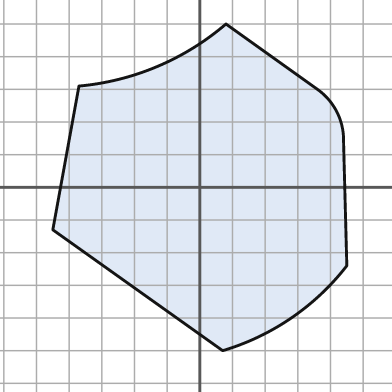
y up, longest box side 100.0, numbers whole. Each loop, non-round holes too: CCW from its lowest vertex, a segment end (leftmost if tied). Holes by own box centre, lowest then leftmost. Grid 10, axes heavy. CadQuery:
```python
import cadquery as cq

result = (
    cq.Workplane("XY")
    .moveTo(7.0, -50.0)
    .threePointArc((28.0, -40.0), (45.0, -24.0))
    .lineTo(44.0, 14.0)
    .threePointArc((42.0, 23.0), (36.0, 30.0))
    .lineTo(8.0, 50.0)
    .threePointArc((-13.0, 37.0), (-37.0, 31.0))
    .lineTo(-45.0, -13.0)
    .close()
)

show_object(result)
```